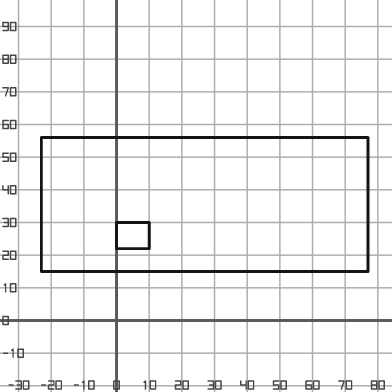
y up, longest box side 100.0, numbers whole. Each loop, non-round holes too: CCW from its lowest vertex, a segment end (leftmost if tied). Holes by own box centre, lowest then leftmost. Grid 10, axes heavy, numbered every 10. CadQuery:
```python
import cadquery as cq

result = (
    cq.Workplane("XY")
    .moveTo(-23.0, 15.0)
    .lineTo(77.0, 15.0)
    .lineTo(77.0, 56.0)
    .lineTo(-23.0, 56.0)
    .close()
    .moveTo(0.0, 22.0)
    .lineTo(10.0, 22.0)
    .lineTo(10.0, 30.0)
    .lineTo(0.0, 30.0)
    .close()
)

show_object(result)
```